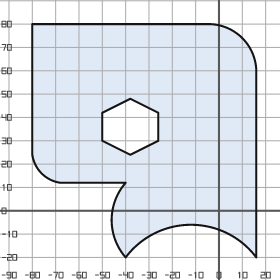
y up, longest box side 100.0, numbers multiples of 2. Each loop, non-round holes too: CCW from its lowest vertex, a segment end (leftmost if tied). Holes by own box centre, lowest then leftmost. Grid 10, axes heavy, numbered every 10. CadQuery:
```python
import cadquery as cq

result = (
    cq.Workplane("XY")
    .moveTo(-40.0, -20.0)
    .threePointArc((-12.0, -6.0), (16.0, -20.0))
    .lineTo(16.0, 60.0)
    .threePointArc((10.0, 74.0), (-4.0, 80.0))
    .lineTo(-80.0, 80.0)
    .lineTo(-80.0, 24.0)
    .threePointArc((-76.0, 16.0), (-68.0, 12.0))
    .lineTo(-40.0, 12.0)
    .threePointArc((-46.0, -4.0), (-40.0, -20.0))
    .close()
    .moveTo(-38.0, 24.0)
    .lineTo(-26.0, 30.0)
    .lineTo(-26.0, 42.0)
    .lineTo(-38.0, 48.0)
    .lineTo(-50.0, 42.0)
    .lineTo(-50.0, 30.0)
    .close()
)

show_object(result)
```